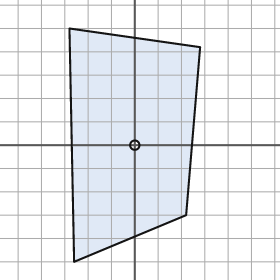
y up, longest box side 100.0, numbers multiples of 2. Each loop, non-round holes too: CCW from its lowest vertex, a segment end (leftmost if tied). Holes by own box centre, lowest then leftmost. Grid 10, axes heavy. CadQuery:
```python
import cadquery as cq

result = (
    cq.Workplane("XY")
    .moveTo(-26.0, -50.0)
    .lineTo(22.0, -30.0)
    .lineTo(28.0, 42.0)
    .lineTo(-28.0, 50.0)
    .close()
    .moveTo(0.0, 0.0)
    .circle(2.0)
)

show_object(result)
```